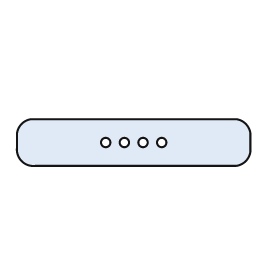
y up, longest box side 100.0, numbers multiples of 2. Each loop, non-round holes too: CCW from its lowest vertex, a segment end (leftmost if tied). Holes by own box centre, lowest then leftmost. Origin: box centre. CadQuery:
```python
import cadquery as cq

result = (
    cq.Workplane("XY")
    .moveTo(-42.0, -10.0)
    .lineTo(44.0, -10.0)
    .threePointArc((48.0, -8.0), (50.0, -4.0))
    .lineTo(50.0, 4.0)
    .threePointArc((48.0, 8.0), (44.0, 10.0))
    .lineTo(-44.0, 10.0)
    .threePointArc((-48.0, 8.0), (-50.0, 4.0))
    .lineTo(-50.0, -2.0)
    .threePointArc((-48.0, -8.0), (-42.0, -10.0))
    .close()
    .moveTo(-12.0, 0.0)
    .circle(2.0)
    .moveTo(-4.0, 0.0)
    .circle(2.0)
    .moveTo(4.0, 0.0)
    .circle(2.0)
    .moveTo(12.0, 0.0)
    .circle(2.0)
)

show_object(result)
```